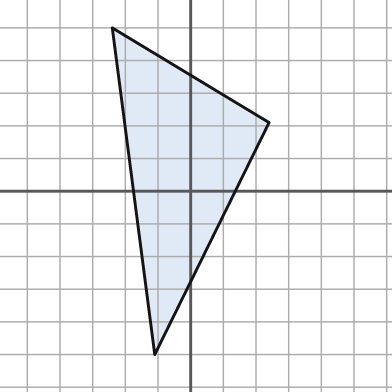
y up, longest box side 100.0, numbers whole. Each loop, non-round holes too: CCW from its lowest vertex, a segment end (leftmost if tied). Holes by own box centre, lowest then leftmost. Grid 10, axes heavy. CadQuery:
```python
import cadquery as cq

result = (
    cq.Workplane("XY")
    .moveTo(-11.0, -50.0)
    .lineTo(24.0, 21.0)
    .lineTo(-24.0, 50.0)
    .close()
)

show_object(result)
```